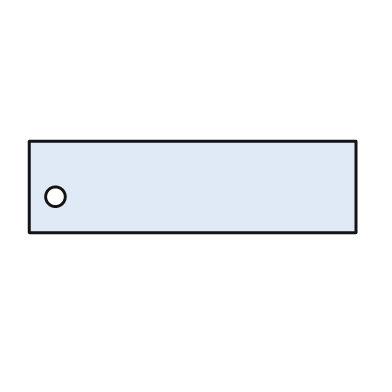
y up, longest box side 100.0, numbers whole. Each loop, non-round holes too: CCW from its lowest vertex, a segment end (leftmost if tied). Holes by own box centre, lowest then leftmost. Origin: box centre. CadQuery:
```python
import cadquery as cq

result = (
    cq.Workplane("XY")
    .moveTo(-50.0, -14.0)
    .lineTo(50.0, -14.0)
    .lineTo(50.0, 14.0)
    .lineTo(-50.0, 14.0)
    .close()
    .moveTo(-42.0, -3.0)
    .circle(3.0)
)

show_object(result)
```